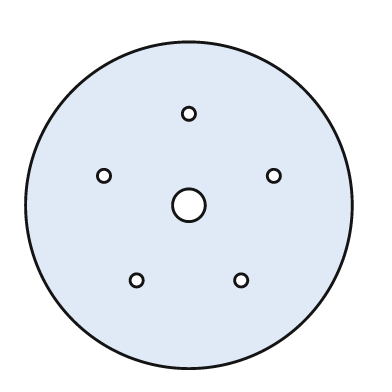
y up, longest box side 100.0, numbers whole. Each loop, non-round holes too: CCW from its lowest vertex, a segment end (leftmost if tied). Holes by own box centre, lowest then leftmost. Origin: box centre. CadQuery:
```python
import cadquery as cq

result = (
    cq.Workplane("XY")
    .moveTo(0.0, 0.0)
    .circle(50.0)
    .moveTo(-16.0, -23.0)
    .circle(2.0)
    .moveTo(16.0, -23.0)
    .circle(2.0)
    .moveTo(0.0, 0.0)
    .circle(5.0)
    .moveTo(-26.0, 9.0)
    .circle(2.0)
    .moveTo(26.0, 9.0)
    .circle(2.0)
    .moveTo(0.0, 28.0)
    .circle(2.0)
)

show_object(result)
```